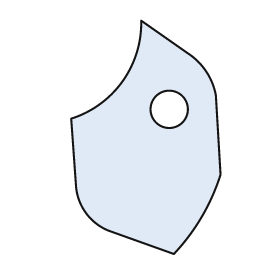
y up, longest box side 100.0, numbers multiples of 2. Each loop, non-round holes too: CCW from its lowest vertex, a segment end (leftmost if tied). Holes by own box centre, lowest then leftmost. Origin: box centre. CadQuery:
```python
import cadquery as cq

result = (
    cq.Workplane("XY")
    .moveTo(12.0, -50.0)
    .threePointArc((24.0, -34.0), (32.0, -16.0))
    .lineTo(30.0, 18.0)
    .threePointArc((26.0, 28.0), (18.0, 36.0))
    .lineTo(-2.0, 50.0)
    .threePointArc((-10.0, 24.0), (-32.0, 8.0))
    .lineTo(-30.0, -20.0)
    .threePointArc((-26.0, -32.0), (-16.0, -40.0))
    .close()
    .moveTo(10.0, 12.0)
    .circle(8.0)
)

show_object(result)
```